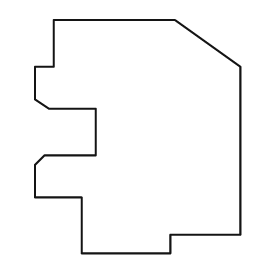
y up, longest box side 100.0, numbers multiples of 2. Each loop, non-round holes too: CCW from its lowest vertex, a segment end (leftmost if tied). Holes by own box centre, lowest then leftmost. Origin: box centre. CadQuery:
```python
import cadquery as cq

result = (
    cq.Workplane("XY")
    .moveTo(-24.0, -50.0)
    .lineTo(14.0, -50.0)
    .lineTo(14.0, -42.0)
    .lineTo(44.0, -42.0)
    .lineTo(44.0, 30.0)
    .lineTo(16.0, 50.0)
    .lineTo(-36.0, 50.0)
    .lineTo(-36.0, 30.0)
    .lineTo(-44.0, 30.0)
    .lineTo(-44.0, 16.0)
    .lineTo(-38.0, 12.0)
    .lineTo(-18.0, 12.0)
    .lineTo(-18.0, -8.0)
    .lineTo(-40.0, -8.0)
    .lineTo(-44.0, -12.0)
    .lineTo(-44.0, -26.0)
    .lineTo(-24.0, -26.0)
    .close()
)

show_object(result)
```